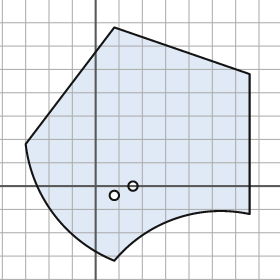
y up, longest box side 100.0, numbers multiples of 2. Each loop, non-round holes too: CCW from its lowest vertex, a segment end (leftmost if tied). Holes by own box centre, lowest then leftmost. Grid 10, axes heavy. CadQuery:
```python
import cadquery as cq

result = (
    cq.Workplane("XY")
    .moveTo(8.0, -32.0)
    .threePointArc((34.0, -14.0), (66.0, -12.0))
    .lineTo(66.0, 48.0)
    .lineTo(8.0, 68.0)
    .lineTo(-30.0, 18.0)
    .threePointArc((-18.0, -12.0), (8.0, -32.0))
    .close()
    .moveTo(8.0, -4.0)
    .circle(2.0)
    .moveTo(16.0, 0.0)
    .circle(2.0)
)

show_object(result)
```